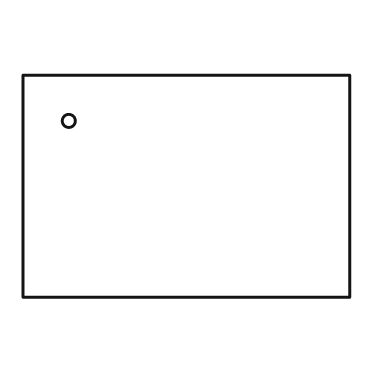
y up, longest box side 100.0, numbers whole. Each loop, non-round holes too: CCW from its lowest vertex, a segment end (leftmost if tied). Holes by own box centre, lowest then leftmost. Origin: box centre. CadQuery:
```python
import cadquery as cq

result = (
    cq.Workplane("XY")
    .moveTo(-50.0, -34.0)
    .lineTo(50.0, -34.0)
    .lineTo(50.0, 34.0)
    .lineTo(-50.0, 34.0)
    .close()
    .moveTo(-36.0, 20.0)
    .circle(2.0)
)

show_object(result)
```